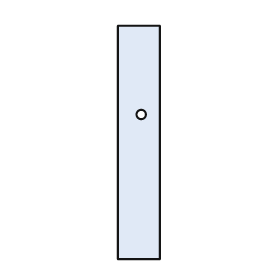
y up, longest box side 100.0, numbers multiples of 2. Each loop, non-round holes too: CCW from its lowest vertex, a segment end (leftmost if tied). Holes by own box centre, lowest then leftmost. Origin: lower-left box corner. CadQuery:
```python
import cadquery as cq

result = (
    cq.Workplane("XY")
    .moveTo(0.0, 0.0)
    .lineTo(18.0, 0.0)
    .lineTo(18.0, 100.0)
    .lineTo(0.0, 100.0)
    .close()
    .moveTo(10.0, 62.0)
    .circle(2.0)
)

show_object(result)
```